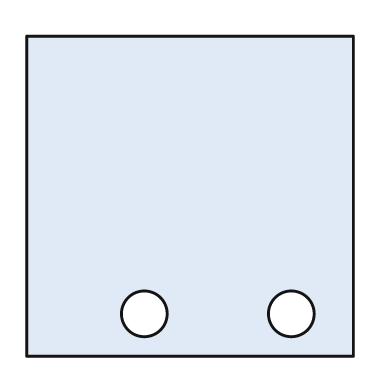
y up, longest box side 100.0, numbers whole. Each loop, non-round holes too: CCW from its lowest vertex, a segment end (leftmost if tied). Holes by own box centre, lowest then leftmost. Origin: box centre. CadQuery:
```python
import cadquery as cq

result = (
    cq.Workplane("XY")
    .moveTo(-50.0, -49.0)
    .lineTo(50.0, -49.0)
    .lineTo(50.0, 49.0)
    .lineTo(-50.0, 49.0)
    .close()
    .moveTo(-14.0, -36.0)
    .circle(7.0)
    .moveTo(31.0, -36.0)
    .circle(7.0)
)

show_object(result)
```